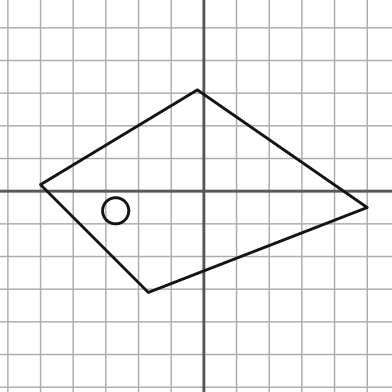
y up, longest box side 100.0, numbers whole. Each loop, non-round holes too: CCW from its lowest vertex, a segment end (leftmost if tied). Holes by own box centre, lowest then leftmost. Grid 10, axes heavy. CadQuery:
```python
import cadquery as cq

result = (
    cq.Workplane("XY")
    .moveTo(-17.0, -31.0)
    .lineTo(50.0, -5.0)
    .lineTo(-2.0, 31.0)
    .lineTo(-50.0, 2.0)
    .close()
    .moveTo(-27.0, -6.0)
    .circle(4.0)
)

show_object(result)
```